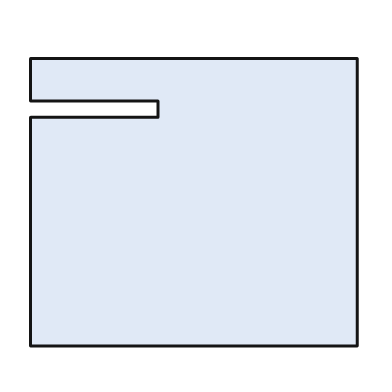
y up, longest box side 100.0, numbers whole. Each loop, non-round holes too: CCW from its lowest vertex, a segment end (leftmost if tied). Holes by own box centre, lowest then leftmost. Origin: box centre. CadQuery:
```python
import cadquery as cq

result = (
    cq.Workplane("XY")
    .moveTo(-50.0, -44.0)
    .lineTo(50.0, -44.0)
    .lineTo(50.0, 44.0)
    .lineTo(-50.0, 44.0)
    .lineTo(-50.0, 31.0)
    .lineTo(-11.0, 31.0)
    .lineTo(-11.0, 26.0)
    .lineTo(-50.0, 26.0)
    .close()
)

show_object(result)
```